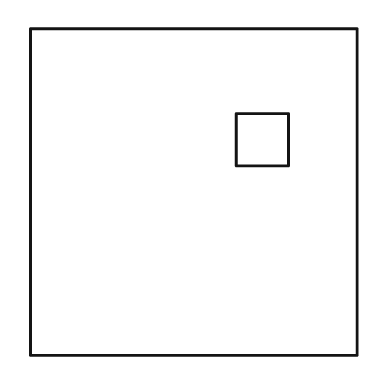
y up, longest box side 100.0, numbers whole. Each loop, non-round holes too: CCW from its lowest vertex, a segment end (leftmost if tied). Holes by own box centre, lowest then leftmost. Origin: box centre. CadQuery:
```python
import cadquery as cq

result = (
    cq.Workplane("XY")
    .moveTo(-50.0, -50.0)
    .lineTo(50.0, -50.0)
    .lineTo(50.0, 50.0)
    .lineTo(-50.0, 50.0)
    .close()
    .moveTo(13.0, 8.0)
    .lineTo(29.0, 8.0)
    .lineTo(29.0, 24.0)
    .lineTo(13.0, 24.0)
    .close()
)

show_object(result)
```